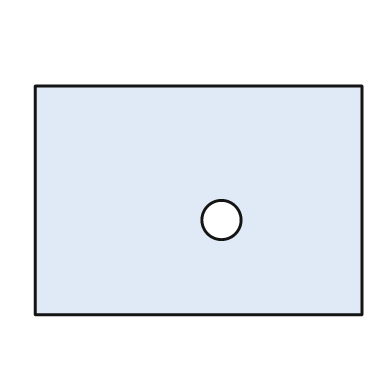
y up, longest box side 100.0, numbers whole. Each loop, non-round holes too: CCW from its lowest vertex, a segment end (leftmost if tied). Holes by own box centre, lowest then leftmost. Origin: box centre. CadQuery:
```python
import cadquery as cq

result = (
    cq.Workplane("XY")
    .moveTo(-50.0, -35.0)
    .lineTo(50.0, -35.0)
    .lineTo(50.0, 35.0)
    .lineTo(-50.0, 35.0)
    .close()
    .moveTo(7.0, -6.0)
    .circle(6.0)
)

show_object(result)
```